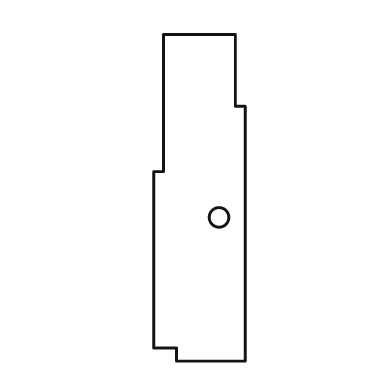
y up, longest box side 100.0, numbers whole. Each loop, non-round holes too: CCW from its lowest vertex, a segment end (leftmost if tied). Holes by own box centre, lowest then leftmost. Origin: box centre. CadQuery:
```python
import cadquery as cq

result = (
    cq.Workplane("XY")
    .moveTo(-7.0, -50.0)
    .lineTo(14.0, -50.0)
    .lineTo(14.0, 28.0)
    .lineTo(11.0, 28.0)
    .lineTo(11.0, 50.0)
    .lineTo(-11.0, 50.0)
    .lineTo(-11.0, 8.0)
    .lineTo(-14.0, 8.0)
    .lineTo(-14.0, -46.0)
    .lineTo(-7.0, -46.0)
    .close()
    .moveTo(6.0, -6.0)
    .circle(3.0)
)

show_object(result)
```